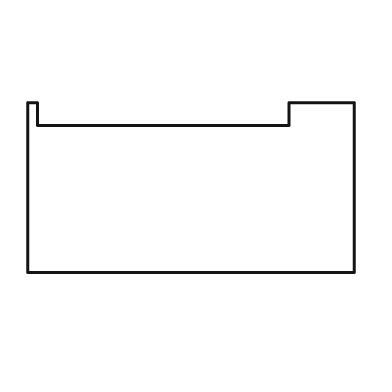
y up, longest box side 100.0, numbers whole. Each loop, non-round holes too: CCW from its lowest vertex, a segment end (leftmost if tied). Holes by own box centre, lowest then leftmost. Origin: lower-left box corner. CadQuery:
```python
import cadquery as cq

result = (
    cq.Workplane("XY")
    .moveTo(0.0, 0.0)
    .lineTo(100.0, 0.0)
    .lineTo(100.0, 52.0)
    .lineTo(80.0, 52.0)
    .lineTo(80.0, 45.0)
    .lineTo(3.0, 45.0)
    .lineTo(3.0, 52.0)
    .lineTo(0.0, 52.0)
    .close()
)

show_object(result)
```